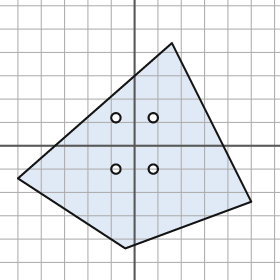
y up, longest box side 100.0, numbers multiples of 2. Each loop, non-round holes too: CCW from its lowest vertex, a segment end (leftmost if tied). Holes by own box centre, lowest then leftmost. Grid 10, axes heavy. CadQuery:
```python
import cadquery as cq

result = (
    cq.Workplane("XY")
    .moveTo(-4.0, -44.0)
    .lineTo(50.0, -24.0)
    .lineTo(16.0, 44.0)
    .lineTo(-50.0, -14.0)
    .close()
    .moveTo(-8.0, -10.0)
    .circle(2.0)
    .moveTo(8.0, -10.0)
    .circle(2.0)
    .moveTo(-8.0, 12.0)
    .circle(2.0)
    .moveTo(8.0, 12.0)
    .circle(2.0)
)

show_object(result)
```